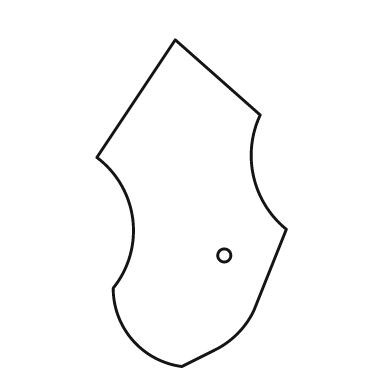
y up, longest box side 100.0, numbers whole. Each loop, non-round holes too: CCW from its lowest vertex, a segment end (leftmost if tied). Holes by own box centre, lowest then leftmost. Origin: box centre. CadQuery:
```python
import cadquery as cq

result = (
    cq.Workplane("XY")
    .moveTo(-3.0, -50.0)
    .lineTo(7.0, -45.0)
    .threePointArc((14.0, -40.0), (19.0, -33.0))
    .lineTo(29.0, -8.0)
    .threePointArc((19.0, 8.0), (21.0, 27.0))
    .lineTo(-5.0, 50.0)
    .lineTo(-29.0, 14.0)
    .threePointArc((-18.0, -5.0), (-24.0, -26.0))
    .threePointArc((-18.0, -42.0), (-3.0, -50.0))
    .close()
    .moveTo(10.0, -16.0)
    .circle(2.0)
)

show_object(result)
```